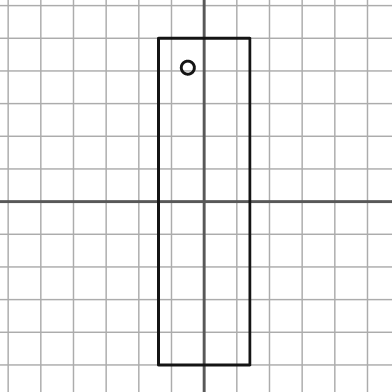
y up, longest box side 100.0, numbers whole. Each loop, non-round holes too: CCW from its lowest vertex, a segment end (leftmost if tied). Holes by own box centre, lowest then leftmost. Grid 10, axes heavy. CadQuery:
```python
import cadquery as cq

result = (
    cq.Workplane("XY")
    .moveTo(-14.0, -50.0)
    .lineTo(14.0, -50.0)
    .lineTo(14.0, 50.0)
    .lineTo(-14.0, 50.0)
    .close()
    .moveTo(-5.0, 41.0)
    .circle(2.0)
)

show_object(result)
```